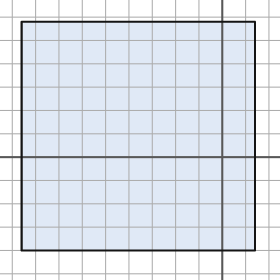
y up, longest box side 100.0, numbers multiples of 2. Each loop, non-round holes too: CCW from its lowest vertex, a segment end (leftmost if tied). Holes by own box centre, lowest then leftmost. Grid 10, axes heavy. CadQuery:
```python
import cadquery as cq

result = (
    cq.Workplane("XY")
    .moveTo(-86.0, -40.0)
    .lineTo(14.0, -40.0)
    .lineTo(14.0, 58.0)
    .lineTo(-86.0, 58.0)
    .close()
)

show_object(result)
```